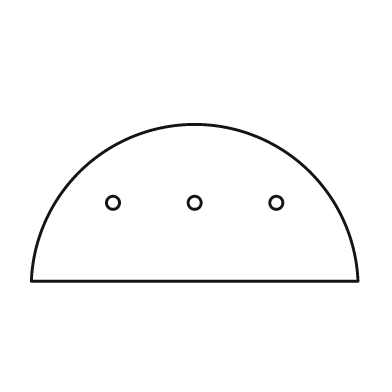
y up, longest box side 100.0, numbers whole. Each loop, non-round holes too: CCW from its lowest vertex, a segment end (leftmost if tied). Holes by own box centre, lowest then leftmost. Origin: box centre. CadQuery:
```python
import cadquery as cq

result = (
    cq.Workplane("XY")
    .moveTo(-50.0, -24.0)
    .lineTo(50.0, -24.0)
    .threePointArc((0.0, 24.0), (-50.0, -24.0))
    .close()
    .moveTo(-25.0, 0.0)
    .circle(2.0)
    .moveTo(0.0, 0.0)
    .circle(2.0)
    .moveTo(25.0, 0.0)
    .circle(2.0)
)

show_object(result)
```